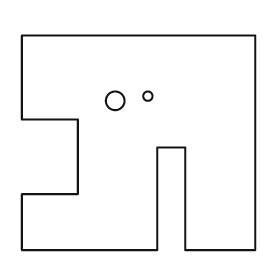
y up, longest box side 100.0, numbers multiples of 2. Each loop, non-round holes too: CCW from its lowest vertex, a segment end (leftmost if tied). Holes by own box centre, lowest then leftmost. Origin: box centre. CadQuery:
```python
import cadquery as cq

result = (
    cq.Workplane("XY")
    .moveTo(-50.0, -46.0)
    .lineTo(8.0, -46.0)
    .lineTo(8.0, -2.0)
    .lineTo(20.0, -2.0)
    .lineTo(20.0, -46.0)
    .lineTo(50.0, -46.0)
    .lineTo(50.0, 46.0)
    .lineTo(-50.0, 46.0)
    .lineTo(-50.0, 10.0)
    .lineTo(-26.0, 10.0)
    .lineTo(-26.0, -22.0)
    .lineTo(-50.0, -22.0)
    .close()
    .moveTo(-10.0, 18.0)
    .circle(4.0)
    .moveTo(4.0, 20.0)
    .circle(2.0)
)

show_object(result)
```